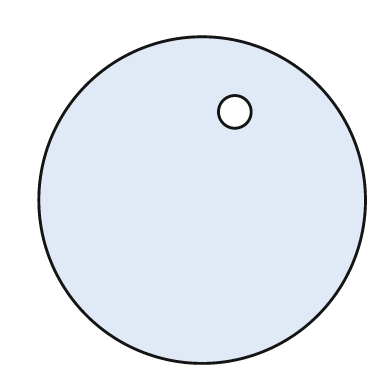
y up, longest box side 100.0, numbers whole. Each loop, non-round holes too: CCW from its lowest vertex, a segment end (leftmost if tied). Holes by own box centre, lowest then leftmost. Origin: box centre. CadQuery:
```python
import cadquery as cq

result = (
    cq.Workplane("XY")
    .moveTo(0.0, 0.0)
    .circle(50.0)
    .moveTo(10.0, 27.0)
    .circle(5.0)
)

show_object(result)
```